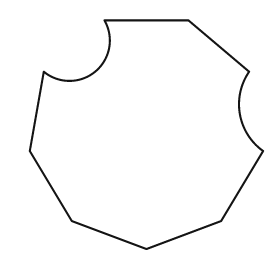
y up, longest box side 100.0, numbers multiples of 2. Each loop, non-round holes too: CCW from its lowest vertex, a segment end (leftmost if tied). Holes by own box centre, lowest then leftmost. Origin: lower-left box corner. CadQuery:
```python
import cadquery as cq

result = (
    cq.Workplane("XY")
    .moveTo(50.0, 0.0)
    .lineTo(82.0, 12.0)
    .lineTo(100.0, 42.0)
    .threePointArc((90.0, 58.0), (94.0, 76.0))
    .lineTo(68.0, 98.0)
    .lineTo(32.0, 98.0)
    .threePointArc((28.0, 76.0), (6.0, 76.0))
    .lineTo(0.0, 42.0)
    .lineTo(18.0, 12.0)
    .close()
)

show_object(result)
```